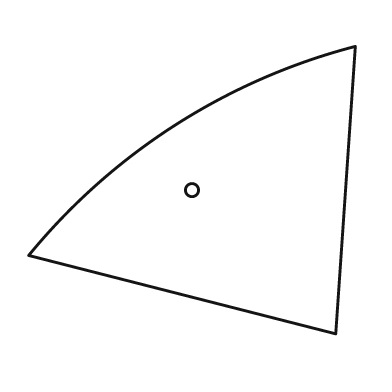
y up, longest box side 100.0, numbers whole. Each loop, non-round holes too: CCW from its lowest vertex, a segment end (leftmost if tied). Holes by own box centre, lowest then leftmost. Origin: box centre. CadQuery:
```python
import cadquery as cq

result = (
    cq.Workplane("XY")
    .moveTo(44.0, -44.0)
    .lineTo(50.0, 44.0)
    .threePointArc((-5.0, 20.0), (-50.0, -20.0))
    .close()
    .moveTo(0.0, 0.0)
    .circle(2.0)
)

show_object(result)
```